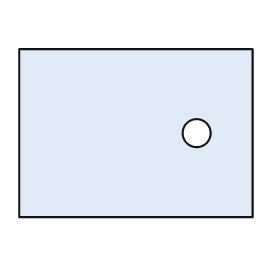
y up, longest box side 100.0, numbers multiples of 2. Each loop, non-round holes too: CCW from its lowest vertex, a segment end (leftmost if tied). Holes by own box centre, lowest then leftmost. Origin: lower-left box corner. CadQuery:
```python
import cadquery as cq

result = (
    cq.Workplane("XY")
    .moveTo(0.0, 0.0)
    .lineTo(100.0, 0.0)
    .lineTo(100.0, 72.0)
    .lineTo(0.0, 72.0)
    .close()
    .moveTo(76.0, 36.0)
    .circle(6.0)
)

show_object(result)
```